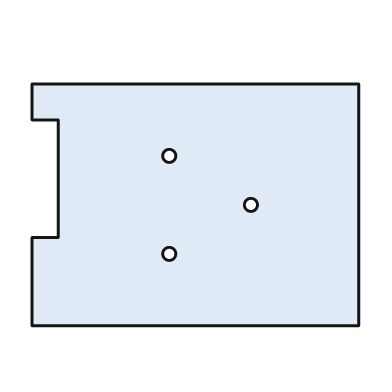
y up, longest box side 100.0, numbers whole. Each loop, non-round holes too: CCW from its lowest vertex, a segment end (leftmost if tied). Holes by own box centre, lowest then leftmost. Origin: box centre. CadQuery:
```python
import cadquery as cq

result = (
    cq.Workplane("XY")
    .moveTo(-50.0, -37.0)
    .lineTo(50.0, -37.0)
    .lineTo(50.0, 37.0)
    .lineTo(-50.0, 37.0)
    .lineTo(-50.0, 26.0)
    .lineTo(-42.0, 26.0)
    .lineTo(-42.0, -10.0)
    .lineTo(-50.0, -10.0)
    .close()
    .moveTo(-8.0, -15.0)
    .circle(2.0)
    .moveTo(17.0, 0.0)
    .circle(2.0)
    .moveTo(-8.0, 15.0)
    .circle(2.0)
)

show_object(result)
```